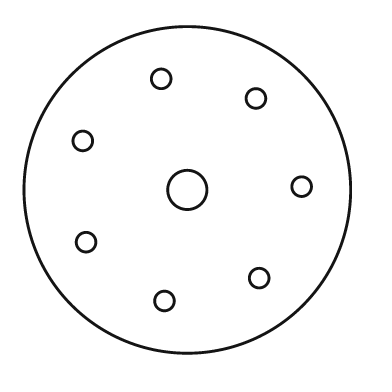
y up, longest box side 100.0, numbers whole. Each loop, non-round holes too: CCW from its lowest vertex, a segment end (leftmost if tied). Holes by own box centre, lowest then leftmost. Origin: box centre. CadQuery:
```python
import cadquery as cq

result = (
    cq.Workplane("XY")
    .moveTo(0.0, 0.0)
    .circle(50.0)
    .moveTo(-7.0, -34.0)
    .circle(3.0)
    .moveTo(22.0, -27.0)
    .circle(3.0)
    .moveTo(-31.0, -16.0)
    .circle(3.0)
    .moveTo(0.0, 0.0)
    .circle(6.0)
    .moveTo(35.0, 1.0)
    .circle(3.0)
    .moveTo(-32.0, 15.0)
    .circle(3.0)
    .moveTo(21.0, 28.0)
    .circle(3.0)
    .moveTo(-8.0, 34.0)
    .circle(3.0)
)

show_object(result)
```